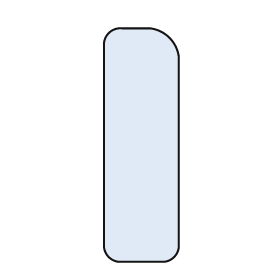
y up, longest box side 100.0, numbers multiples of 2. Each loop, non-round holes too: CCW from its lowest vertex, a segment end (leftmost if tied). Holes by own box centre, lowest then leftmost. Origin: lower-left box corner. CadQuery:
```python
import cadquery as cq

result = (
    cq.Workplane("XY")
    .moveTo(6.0, 0.0)
    .lineTo(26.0, 0.0)
    .threePointArc((30.0, 2.0), (32.0, 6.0))
    .lineTo(32.0, 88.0)
    .threePointArc((28.0, 96.0), (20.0, 100.0))
    .lineTo(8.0, 100.0)
    .threePointArc((2.0, 98.0), (0.0, 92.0))
    .lineTo(0.0, 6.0)
    .threePointArc((2.0, 2.0), (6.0, 0.0))
    .close()
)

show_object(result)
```